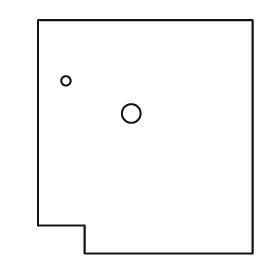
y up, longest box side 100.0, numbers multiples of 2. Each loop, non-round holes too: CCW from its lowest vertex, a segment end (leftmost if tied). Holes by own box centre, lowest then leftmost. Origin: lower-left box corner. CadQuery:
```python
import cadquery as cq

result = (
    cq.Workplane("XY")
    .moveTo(20.0, 0.0)
    .lineTo(92.0, 0.0)
    .lineTo(92.0, 100.0)
    .lineTo(0.0, 100.0)
    .lineTo(0.0, 12.0)
    .lineTo(20.0, 12.0)
    .close()
    .moveTo(40.0, 60.0)
    .circle(4.0)
    .moveTo(12.0, 74.0)
    .circle(2.0)
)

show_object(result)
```